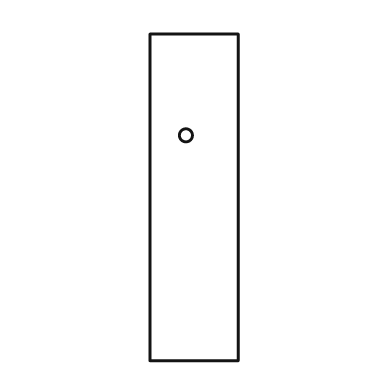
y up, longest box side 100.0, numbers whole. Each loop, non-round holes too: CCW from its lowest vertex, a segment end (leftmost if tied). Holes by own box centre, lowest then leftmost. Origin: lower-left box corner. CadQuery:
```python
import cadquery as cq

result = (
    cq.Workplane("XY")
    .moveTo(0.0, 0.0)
    .lineTo(27.0, 0.0)
    .lineTo(27.0, 100.0)
    .lineTo(0.0, 100.0)
    .close()
    .moveTo(11.0, 69.0)
    .circle(2.0)
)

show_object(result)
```